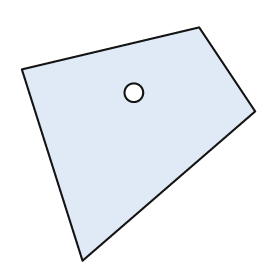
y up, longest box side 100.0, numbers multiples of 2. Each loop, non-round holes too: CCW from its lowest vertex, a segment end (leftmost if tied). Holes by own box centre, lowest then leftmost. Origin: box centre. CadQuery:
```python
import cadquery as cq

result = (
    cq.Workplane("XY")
    .moveTo(-24.0, -50.0)
    .lineTo(50.0, 14.0)
    .lineTo(26.0, 50.0)
    .lineTo(-50.0, 32.0)
    .close()
    .moveTo(-2.0, 22.0)
    .circle(4.0)
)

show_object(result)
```